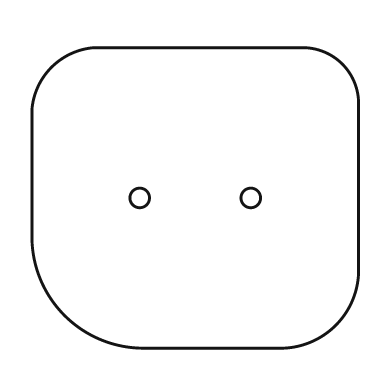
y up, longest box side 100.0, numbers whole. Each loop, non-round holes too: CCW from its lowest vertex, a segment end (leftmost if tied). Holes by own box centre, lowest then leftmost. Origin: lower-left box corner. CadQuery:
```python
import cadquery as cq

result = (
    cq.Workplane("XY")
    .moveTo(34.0, 0.0)
    .lineTo(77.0, 0.0)
    .threePointArc((93.0, 7.0), (100.0, 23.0))
    .lineTo(100.0, 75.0)
    .threePointArc((95.0, 87.0), (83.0, 92.0))
    .lineTo(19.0, 92.0)
    .threePointArc((6.0, 86.0), (0.0, 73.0))
    .lineTo(0.0, 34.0)
    .threePointArc((10.0, 10.0), (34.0, 0.0))
    .close()
    .moveTo(33.0, 46.0)
    .circle(3.0)
    .moveTo(67.0, 46.0)
    .circle(3.0)
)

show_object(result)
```